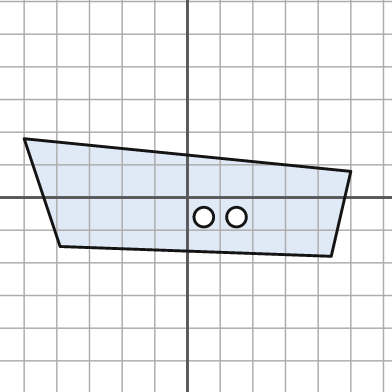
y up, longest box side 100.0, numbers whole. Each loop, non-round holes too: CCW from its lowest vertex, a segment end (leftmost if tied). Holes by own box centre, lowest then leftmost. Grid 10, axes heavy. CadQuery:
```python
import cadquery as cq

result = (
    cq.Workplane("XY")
    .moveTo(44.0, -18.0)
    .lineTo(50.0, 8.0)
    .lineTo(-50.0, 18.0)
    .lineTo(-39.0, -15.0)
    .close()
    .moveTo(5.0, -6.0)
    .circle(3.0)
    .moveTo(15.0, -6.0)
    .circle(3.0)
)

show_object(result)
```